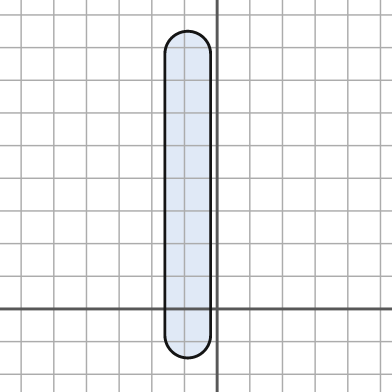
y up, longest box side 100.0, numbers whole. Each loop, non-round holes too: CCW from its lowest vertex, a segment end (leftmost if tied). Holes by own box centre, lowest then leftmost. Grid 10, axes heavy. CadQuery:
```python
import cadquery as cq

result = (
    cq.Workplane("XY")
    .moveTo(-16.0, -8.0)
    .threePointArc((-9.0, -15.0), (-2.0, -8.0))
    .lineTo(-2.0, 78.0)
    .threePointArc((-9.0, 85.0), (-16.0, 78.0))
    .close()
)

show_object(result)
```